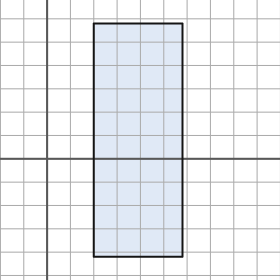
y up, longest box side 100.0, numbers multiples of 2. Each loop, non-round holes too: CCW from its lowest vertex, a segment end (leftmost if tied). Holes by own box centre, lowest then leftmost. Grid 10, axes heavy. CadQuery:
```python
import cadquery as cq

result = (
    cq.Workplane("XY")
    .moveTo(20.0, -42.0)
    .lineTo(58.0, -42.0)
    .lineTo(58.0, 58.0)
    .lineTo(20.0, 58.0)
    .close()
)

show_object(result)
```